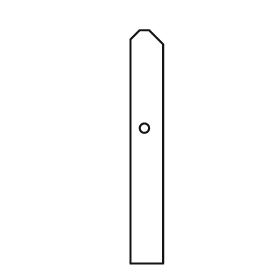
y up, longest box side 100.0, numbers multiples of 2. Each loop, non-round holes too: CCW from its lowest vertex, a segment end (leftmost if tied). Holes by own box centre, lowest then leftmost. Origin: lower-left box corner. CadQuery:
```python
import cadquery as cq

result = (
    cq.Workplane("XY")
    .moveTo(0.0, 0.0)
    .lineTo(14.0, 0.0)
    .lineTo(14.0, 94.0)
    .lineTo(8.0, 100.0)
    .lineTo(4.0, 100.0)
    .lineTo(0.0, 96.0)
    .close()
    .moveTo(6.0, 58.0)
    .circle(2.0)
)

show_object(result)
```